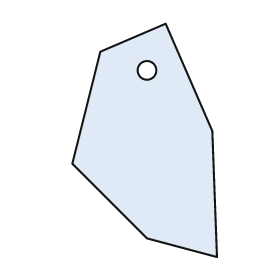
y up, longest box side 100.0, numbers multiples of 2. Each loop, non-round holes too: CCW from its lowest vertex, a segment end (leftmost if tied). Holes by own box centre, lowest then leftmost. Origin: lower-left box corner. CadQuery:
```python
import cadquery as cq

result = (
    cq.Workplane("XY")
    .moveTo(62.0, 0.0)
    .lineTo(60.0, 54.0)
    .lineTo(40.0, 100.0)
    .lineTo(12.0, 88.0)
    .lineTo(0.0, 40.0)
    .lineTo(32.0, 8.0)
    .close()
    .moveTo(32.0, 80.0)
    .circle(4.0)
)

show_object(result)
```